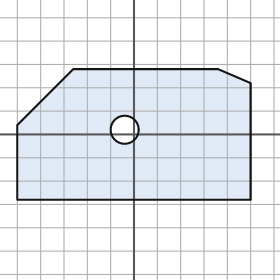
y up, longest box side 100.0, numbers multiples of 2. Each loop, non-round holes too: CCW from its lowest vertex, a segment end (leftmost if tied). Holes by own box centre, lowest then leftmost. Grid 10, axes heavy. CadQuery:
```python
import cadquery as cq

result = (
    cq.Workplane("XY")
    .moveTo(-50.0, -28.0)
    .lineTo(50.0, -28.0)
    .lineTo(50.0, 22.0)
    .lineTo(36.0, 28.0)
    .lineTo(-26.0, 28.0)
    .lineTo(-50.0, 4.0)
    .close()
    .moveTo(-4.0, 2.0)
    .circle(6.0)
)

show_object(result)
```